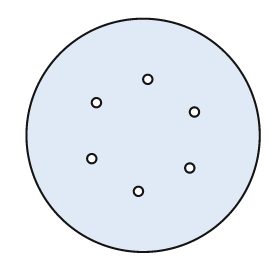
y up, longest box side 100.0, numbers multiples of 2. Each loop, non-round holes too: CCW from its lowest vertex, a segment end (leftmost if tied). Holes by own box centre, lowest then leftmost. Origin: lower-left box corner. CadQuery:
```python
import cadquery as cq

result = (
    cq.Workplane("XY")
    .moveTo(50.0, 50.0)
    .circle(50.0)
    .moveTo(48.0, 26.0)
    .circle(2.0)
    .moveTo(70.0, 36.0)
    .circle(2.0)
    .moveTo(28.0, 40.0)
    .circle(2.0)
    .moveTo(72.0, 60.0)
    .circle(2.0)
    .moveTo(30.0, 64.0)
    .circle(2.0)
    .moveTo(52.0, 74.0)
    .circle(2.0)
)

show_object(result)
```